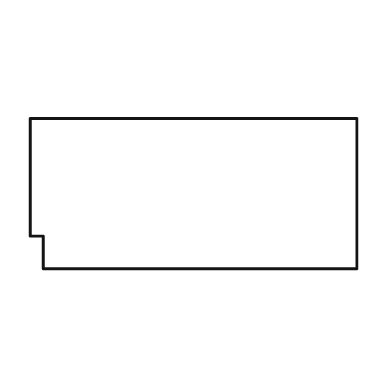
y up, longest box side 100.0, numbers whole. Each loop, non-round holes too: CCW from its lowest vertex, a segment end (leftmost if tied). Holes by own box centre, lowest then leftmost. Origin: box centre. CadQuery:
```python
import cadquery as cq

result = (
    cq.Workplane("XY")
    .moveTo(-46.0, -23.0)
    .lineTo(50.0, -23.0)
    .lineTo(50.0, 23.0)
    .lineTo(-50.0, 23.0)
    .lineTo(-50.0, -13.0)
    .lineTo(-46.0, -13.0)
    .close()
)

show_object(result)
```